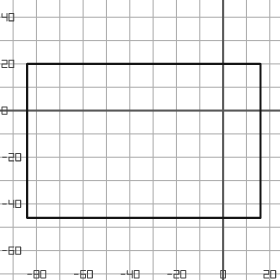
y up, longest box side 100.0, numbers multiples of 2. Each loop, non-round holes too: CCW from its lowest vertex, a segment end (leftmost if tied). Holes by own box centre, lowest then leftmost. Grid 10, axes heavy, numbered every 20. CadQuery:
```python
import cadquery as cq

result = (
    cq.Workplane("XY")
    .moveTo(-84.0, -46.0)
    .lineTo(16.0, -46.0)
    .lineTo(16.0, 20.0)
    .lineTo(-84.0, 20.0)
    .close()
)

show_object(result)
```